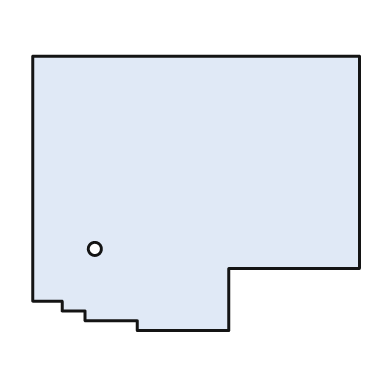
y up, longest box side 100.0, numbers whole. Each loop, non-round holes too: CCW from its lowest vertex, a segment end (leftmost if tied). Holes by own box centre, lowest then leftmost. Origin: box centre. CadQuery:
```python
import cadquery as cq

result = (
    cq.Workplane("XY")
    .moveTo(-18.0, -42.0)
    .lineTo(10.0, -42.0)
    .lineTo(10.0, -23.0)
    .lineTo(50.0, -23.0)
    .lineTo(50.0, 42.0)
    .lineTo(-50.0, 42.0)
    .lineTo(-50.0, -33.0)
    .lineTo(-41.0, -33.0)
    .lineTo(-41.0, -36.0)
    .lineTo(-34.0, -36.0)
    .lineTo(-34.0, -39.0)
    .lineTo(-18.0, -39.0)
    .close()
    .moveTo(-31.0, -17.0)
    .circle(2.0)
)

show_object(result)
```